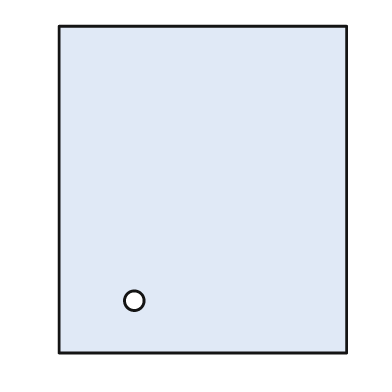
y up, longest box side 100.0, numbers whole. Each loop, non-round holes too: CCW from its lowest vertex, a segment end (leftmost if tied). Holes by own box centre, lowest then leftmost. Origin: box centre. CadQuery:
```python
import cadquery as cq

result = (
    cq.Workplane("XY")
    .moveTo(-44.0, -50.0)
    .lineTo(44.0, -50.0)
    .lineTo(44.0, 50.0)
    .lineTo(-44.0, 50.0)
    .close()
    .moveTo(-21.0, -34.0)
    .circle(3.0)
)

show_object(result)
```